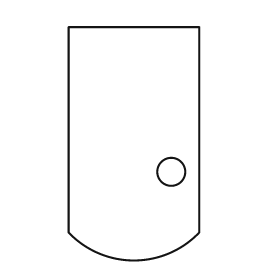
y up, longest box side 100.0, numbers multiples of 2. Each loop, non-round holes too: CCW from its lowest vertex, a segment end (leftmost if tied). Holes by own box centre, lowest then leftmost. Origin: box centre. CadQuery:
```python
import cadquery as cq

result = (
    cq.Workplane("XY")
    .moveTo(-28.0, -38.0)
    .threePointArc((0.0, -50.0), (28.0, -38.0))
    .lineTo(28.0, 50.0)
    .lineTo(-28.0, 50.0)
    .close()
    .moveTo(16.0, -12.0)
    .circle(6.0)
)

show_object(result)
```